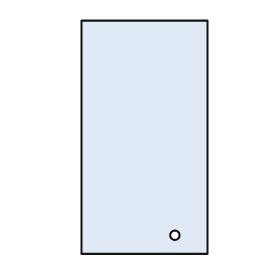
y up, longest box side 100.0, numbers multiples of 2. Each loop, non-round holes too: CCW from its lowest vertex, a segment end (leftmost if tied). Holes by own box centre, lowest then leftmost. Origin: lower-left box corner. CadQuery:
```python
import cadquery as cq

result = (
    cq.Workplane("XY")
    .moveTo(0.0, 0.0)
    .lineTo(54.0, 0.0)
    .lineTo(54.0, 100.0)
    .lineTo(0.0, 100.0)
    .close()
    .moveTo(40.0, 8.0)
    .circle(2.0)
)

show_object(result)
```